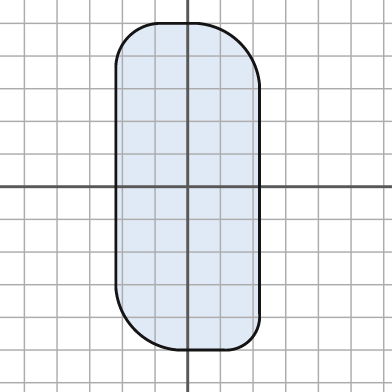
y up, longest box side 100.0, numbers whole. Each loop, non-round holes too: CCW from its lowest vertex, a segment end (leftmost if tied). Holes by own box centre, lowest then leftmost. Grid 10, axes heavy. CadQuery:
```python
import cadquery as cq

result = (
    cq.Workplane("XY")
    .moveTo(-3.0, -50.0)
    .lineTo(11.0, -50.0)
    .threePointArc((19.0, -47.0), (22.0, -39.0))
    .lineTo(22.0, 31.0)
    .threePointArc((16.0, 44.0), (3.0, 50.0))
    .lineTo(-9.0, 50.0)
    .threePointArc((-18.0, 46.0), (-22.0, 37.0))
    .lineTo(-22.0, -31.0)
    .threePointArc((-16.0, -44.0), (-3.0, -50.0))
    .close()
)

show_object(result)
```